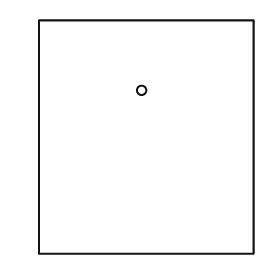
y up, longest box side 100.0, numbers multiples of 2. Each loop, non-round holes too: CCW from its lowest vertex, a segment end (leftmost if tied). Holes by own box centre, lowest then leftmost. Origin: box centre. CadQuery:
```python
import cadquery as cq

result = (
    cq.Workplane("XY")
    .moveTo(-46.0, -50.0)
    .lineTo(46.0, -50.0)
    .lineTo(46.0, 50.0)
    .lineTo(-46.0, 50.0)
    .close()
    .moveTo(-2.0, 20.0)
    .circle(2.0)
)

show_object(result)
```